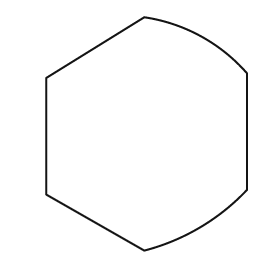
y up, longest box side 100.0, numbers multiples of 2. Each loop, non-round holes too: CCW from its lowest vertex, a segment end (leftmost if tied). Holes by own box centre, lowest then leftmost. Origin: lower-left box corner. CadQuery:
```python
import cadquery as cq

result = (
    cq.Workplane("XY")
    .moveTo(42.0, 0.0)
    .threePointArc((66.0, 10.0), (86.0, 26.0))
    .lineTo(86.0, 76.0)
    .threePointArc((66.0, 92.0), (42.0, 100.0))
    .lineTo(0.0, 74.0)
    .lineTo(0.0, 24.0)
    .close()
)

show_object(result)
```